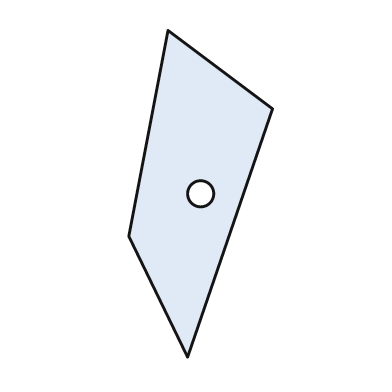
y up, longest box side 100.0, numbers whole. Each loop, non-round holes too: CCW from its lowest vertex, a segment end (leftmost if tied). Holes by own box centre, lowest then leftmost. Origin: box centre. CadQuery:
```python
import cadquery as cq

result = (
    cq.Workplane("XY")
    .moveTo(-4.0, -50.0)
    .lineTo(22.0, 26.0)
    .lineTo(-10.0, 50.0)
    .lineTo(-22.0, -13.0)
    .close()
    .moveTo(0.0, 0.0)
    .circle(4.0)
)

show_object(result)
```